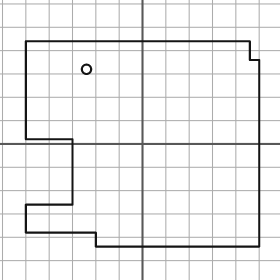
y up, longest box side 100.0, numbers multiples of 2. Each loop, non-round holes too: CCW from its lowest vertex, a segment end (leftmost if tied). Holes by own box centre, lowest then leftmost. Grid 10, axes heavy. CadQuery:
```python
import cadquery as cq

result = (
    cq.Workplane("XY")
    .moveTo(-20.0, -44.0)
    .lineTo(50.0, -44.0)
    .lineTo(50.0, 36.0)
    .lineTo(46.0, 36.0)
    .lineTo(46.0, 44.0)
    .lineTo(-50.0, 44.0)
    .lineTo(-50.0, 2.0)
    .lineTo(-30.0, 2.0)
    .lineTo(-30.0, -26.0)
    .lineTo(-50.0, -26.0)
    .lineTo(-50.0, -38.0)
    .lineTo(-20.0, -38.0)
    .close()
    .moveTo(-24.0, 32.0)
    .circle(2.0)
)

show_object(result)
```